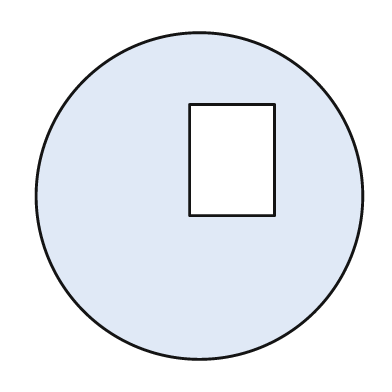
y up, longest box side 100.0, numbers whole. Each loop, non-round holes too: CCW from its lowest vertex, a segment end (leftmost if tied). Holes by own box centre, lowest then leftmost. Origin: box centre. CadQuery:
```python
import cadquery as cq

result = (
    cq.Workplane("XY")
    .moveTo(0.0, 0.0)
    .circle(50.0)
    .moveTo(-3.0, -6.0)
    .lineTo(23.0, -6.0)
    .lineTo(23.0, 28.0)
    .lineTo(-3.0, 28.0)
    .close()
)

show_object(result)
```